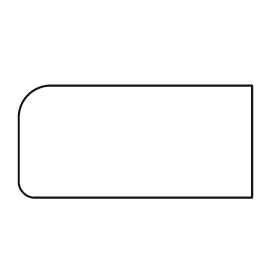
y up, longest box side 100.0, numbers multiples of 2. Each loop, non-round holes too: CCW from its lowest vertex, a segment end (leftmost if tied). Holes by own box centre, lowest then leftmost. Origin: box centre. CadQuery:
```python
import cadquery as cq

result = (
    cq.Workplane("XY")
    .moveTo(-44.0, -24.0)
    .lineTo(50.0, -24.0)
    .lineTo(50.0, 24.0)
    .lineTo(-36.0, 24.0)
    .threePointArc((-46.0, 20.0), (-50.0, 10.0))
    .lineTo(-50.0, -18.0)
    .threePointArc((-48.0, -22.0), (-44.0, -24.0))
    .close()
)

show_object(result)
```